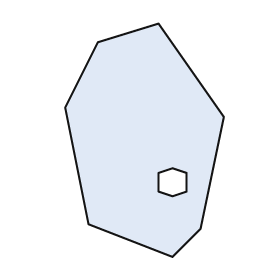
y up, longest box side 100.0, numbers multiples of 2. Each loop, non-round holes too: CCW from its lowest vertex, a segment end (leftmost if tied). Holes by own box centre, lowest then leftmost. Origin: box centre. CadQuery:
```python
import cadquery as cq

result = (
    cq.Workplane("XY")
    .moveTo(12.0, -50.0)
    .lineTo(24.0, -38.0)
    .lineTo(34.0, 10.0)
    .lineTo(6.0, 50.0)
    .lineTo(-20.0, 42.0)
    .lineTo(-34.0, 14.0)
    .lineTo(-24.0, -36.0)
    .close()
    .moveTo(12.0, -24.0)
    .lineTo(18.0, -22.0)
    .lineTo(18.0, -14.0)
    .lineTo(12.0, -12.0)
    .lineTo(6.0, -14.0)
    .lineTo(6.0, -22.0)
    .close()
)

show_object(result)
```